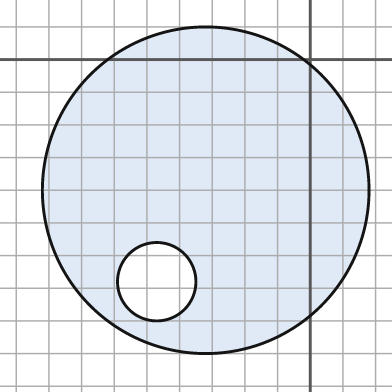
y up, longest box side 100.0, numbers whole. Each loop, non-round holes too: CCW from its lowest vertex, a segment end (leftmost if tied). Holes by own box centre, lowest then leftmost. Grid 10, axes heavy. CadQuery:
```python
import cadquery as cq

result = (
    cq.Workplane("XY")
    .moveTo(-32.0, -40.0)
    .circle(50.0)
    .moveTo(-47.0, -68.0)
    .circle(12.0)
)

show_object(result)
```